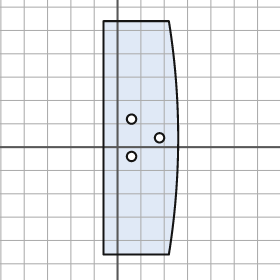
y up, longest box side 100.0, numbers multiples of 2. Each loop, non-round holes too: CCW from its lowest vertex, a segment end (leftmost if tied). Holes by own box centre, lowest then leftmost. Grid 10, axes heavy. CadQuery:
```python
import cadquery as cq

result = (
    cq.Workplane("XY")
    .moveTo(-6.0, -46.0)
    .lineTo(22.0, -46.0)
    .threePointArc((26.0, 4.0), (22.0, 54.0))
    .lineTo(-6.0, 54.0)
    .close()
    .moveTo(6.0, -4.0)
    .circle(2.0)
    .moveTo(18.0, 4.0)
    .circle(2.0)
    .moveTo(6.0, 12.0)
    .circle(2.0)
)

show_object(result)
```